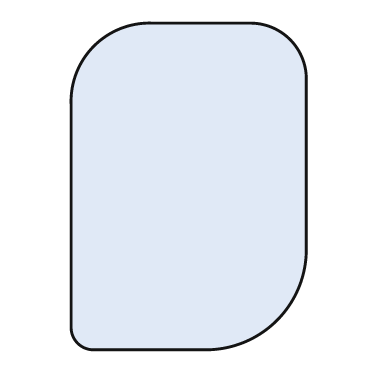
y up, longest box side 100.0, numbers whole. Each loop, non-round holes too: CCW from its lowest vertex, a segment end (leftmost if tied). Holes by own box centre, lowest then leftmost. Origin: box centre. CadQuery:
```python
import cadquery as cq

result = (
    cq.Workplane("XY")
    .moveTo(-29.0, -50.0)
    .lineTo(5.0, -50.0)
    .threePointArc((27.0, -41.0), (36.0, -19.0))
    .lineTo(36.0, 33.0)
    .threePointArc((31.0, 45.0), (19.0, 50.0))
    .lineTo(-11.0, 50.0)
    .threePointArc((-29.0, 43.0), (-36.0, 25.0))
    .lineTo(-36.0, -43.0)
    .threePointArc((-34.0, -48.0), (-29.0, -50.0))
    .close()
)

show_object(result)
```